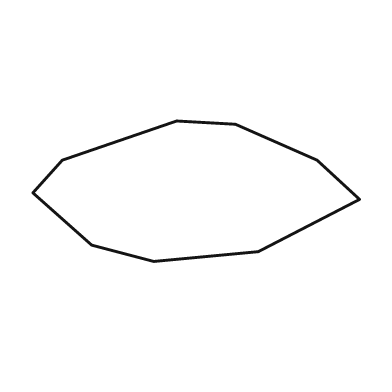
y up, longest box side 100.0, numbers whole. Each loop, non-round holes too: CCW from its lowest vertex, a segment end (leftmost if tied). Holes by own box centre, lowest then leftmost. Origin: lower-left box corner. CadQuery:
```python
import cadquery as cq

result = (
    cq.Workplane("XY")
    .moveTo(37.0, 0.0)
    .lineTo(69.0, 3.0)
    .lineTo(100.0, 19.0)
    .lineTo(87.0, 31.0)
    .lineTo(62.0, 42.0)
    .lineTo(44.0, 43.0)
    .lineTo(9.0, 31.0)
    .lineTo(0.0, 21.0)
    .lineTo(18.0, 5.0)
    .close()
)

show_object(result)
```